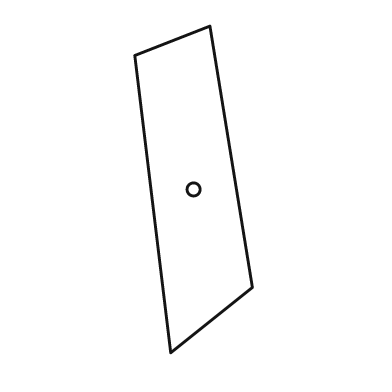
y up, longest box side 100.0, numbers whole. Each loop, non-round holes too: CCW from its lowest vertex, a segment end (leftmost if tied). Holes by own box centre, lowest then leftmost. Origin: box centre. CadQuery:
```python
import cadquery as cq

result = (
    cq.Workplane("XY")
    .moveTo(-7.0, -50.0)
    .lineTo(18.0, -30.0)
    .lineTo(5.0, 50.0)
    .lineTo(-18.0, 41.0)
    .close()
    .moveTo(0.0, 0.0)
    .circle(2.0)
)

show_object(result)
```